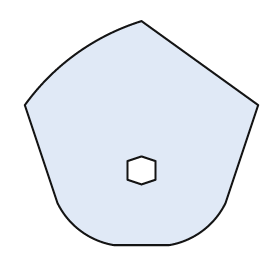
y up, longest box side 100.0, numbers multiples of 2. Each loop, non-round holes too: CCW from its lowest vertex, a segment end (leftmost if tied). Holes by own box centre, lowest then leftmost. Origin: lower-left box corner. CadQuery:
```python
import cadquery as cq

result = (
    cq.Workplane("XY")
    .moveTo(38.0, 0.0)
    .lineTo(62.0, 0.0)
    .threePointArc((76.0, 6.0), (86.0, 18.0))
    .lineTo(100.0, 60.0)
    .lineTo(50.0, 96.0)
    .threePointArc((22.0, 82.0), (0.0, 60.0))
    .lineTo(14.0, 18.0)
    .threePointArc((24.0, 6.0), (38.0, 0.0))
    .close()
    .moveTo(50.0, 26.0)
    .lineTo(56.0, 28.0)
    .lineTo(56.0, 36.0)
    .lineTo(50.0, 38.0)
    .lineTo(44.0, 36.0)
    .lineTo(44.0, 28.0)
    .close()
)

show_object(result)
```